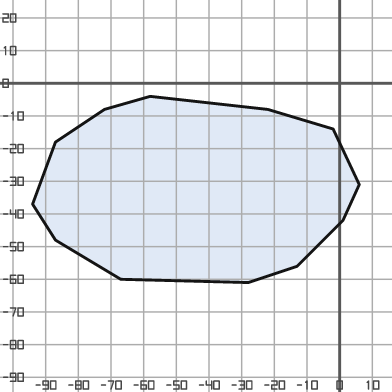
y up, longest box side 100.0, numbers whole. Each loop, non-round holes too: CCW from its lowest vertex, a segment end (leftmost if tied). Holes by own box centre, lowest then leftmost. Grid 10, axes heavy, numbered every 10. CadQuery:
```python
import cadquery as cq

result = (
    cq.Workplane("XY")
    .moveTo(-28.0, -61.0)
    .lineTo(-13.0, -56.0)
    .lineTo(1.0, -42.0)
    .lineTo(6.0, -31.0)
    .lineTo(-2.0, -14.0)
    .lineTo(-22.0, -8.0)
    .lineTo(-58.0, -4.0)
    .lineTo(-72.0, -8.0)
    .lineTo(-87.0, -18.0)
    .lineTo(-94.0, -37.0)
    .lineTo(-87.0, -48.0)
    .lineTo(-67.0, -60.0)
    .close()
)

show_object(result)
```